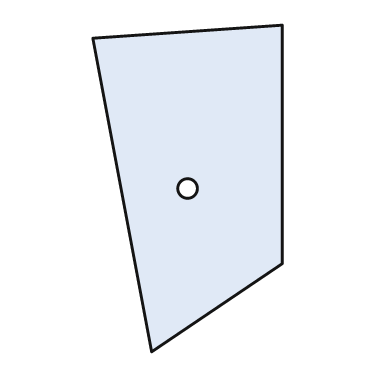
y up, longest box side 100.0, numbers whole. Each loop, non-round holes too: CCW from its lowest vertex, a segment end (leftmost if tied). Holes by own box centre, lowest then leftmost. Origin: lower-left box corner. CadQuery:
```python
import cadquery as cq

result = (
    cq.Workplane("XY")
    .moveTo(18.0, 0.0)
    .lineTo(58.0, 27.0)
    .lineTo(58.0, 100.0)
    .lineTo(0.0, 96.0)
    .close()
    .moveTo(29.0, 50.0)
    .circle(3.0)
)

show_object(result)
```